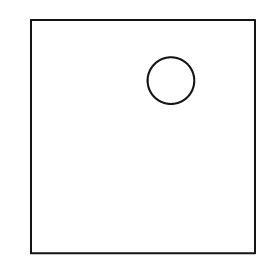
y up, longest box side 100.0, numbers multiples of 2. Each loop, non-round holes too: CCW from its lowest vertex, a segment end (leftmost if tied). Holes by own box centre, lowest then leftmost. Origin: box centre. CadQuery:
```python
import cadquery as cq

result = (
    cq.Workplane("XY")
    .moveTo(-48.0, -50.0)
    .lineTo(48.0, -50.0)
    .lineTo(48.0, 50.0)
    .lineTo(-48.0, 50.0)
    .close()
    .moveTo(12.0, 24.0)
    .circle(10.0)
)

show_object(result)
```